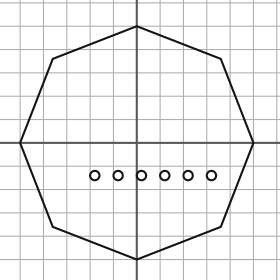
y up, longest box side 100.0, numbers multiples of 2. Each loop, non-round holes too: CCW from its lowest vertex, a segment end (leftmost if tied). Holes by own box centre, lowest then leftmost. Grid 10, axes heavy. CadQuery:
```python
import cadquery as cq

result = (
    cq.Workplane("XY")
    .moveTo(0.0, -50.0)
    .lineTo(36.0, -36.0)
    .lineTo(50.0, 0.0)
    .lineTo(36.0, 36.0)
    .lineTo(0.0, 50.0)
    .lineTo(-36.0, 36.0)
    .lineTo(-50.0, 0.0)
    .lineTo(-36.0, -36.0)
    .close()
    .moveTo(-18.0, -14.0)
    .circle(2.0)
    .moveTo(-8.0, -14.0)
    .circle(2.0)
    .moveTo(2.0, -14.0)
    .circle(2.0)
    .moveTo(12.0, -14.0)
    .circle(2.0)
    .moveTo(22.0, -14.0)
    .circle(2.0)
    .moveTo(32.0, -14.0)
    .circle(2.0)
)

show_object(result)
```